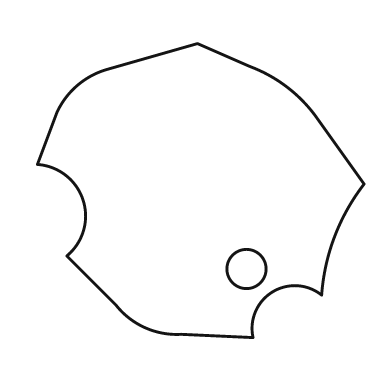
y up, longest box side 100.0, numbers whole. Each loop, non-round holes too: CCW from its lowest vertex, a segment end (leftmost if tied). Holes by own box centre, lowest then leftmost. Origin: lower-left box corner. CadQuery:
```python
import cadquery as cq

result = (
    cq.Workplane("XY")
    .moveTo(66.0, 0.0)
    .threePointArc((72.0, 14.0), (87.0, 13.0))
    .threePointArc((91.0, 31.0), (100.0, 47.0))
    .lineTo(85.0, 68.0)
    .threePointArc((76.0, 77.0), (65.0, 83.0))
    .lineTo(49.0, 90.0)
    .lineTo(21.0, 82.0)
    .threePointArc((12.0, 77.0), (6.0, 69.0))
    .lineTo(0.0, 53.0)
    .threePointArc((14.0, 42.0), (9.0, 25.0))
    .lineTo(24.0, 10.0)
    .threePointArc((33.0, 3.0), (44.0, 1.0))
    .close()
    .moveTo(64.0, 21.0)
    .circle(6.0)
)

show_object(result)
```